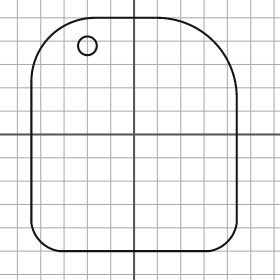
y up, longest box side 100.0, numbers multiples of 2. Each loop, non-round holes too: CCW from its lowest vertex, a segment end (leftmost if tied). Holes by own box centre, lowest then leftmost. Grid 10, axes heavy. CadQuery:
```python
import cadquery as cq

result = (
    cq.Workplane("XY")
    .moveTo(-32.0, -50.0)
    .lineTo(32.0, -50.0)
    .threePointArc((40.0, -46.0), (44.0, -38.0))
    .lineTo(44.0, 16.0)
    .threePointArc((34.0, 40.0), (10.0, 50.0))
    .lineTo(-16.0, 50.0)
    .threePointArc((-36.0, 42.0), (-44.0, 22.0))
    .lineTo(-44.0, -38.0)
    .threePointArc((-40.0, -46.0), (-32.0, -50.0))
    .close()
    .moveTo(-20.0, 38.0)
    .circle(4.0)
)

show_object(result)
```